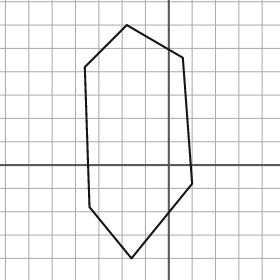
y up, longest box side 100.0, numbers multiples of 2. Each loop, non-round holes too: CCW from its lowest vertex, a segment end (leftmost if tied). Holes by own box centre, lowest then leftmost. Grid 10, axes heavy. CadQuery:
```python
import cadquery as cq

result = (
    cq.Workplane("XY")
    .moveTo(-16.0, -40.0)
    .lineTo(10.0, -8.0)
    .lineTo(6.0, 46.0)
    .lineTo(-18.0, 60.0)
    .lineTo(-36.0, 42.0)
    .lineTo(-34.0, -18.0)
    .close()
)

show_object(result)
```